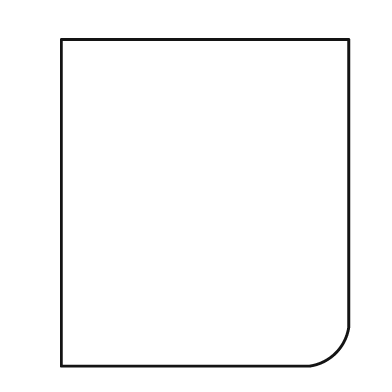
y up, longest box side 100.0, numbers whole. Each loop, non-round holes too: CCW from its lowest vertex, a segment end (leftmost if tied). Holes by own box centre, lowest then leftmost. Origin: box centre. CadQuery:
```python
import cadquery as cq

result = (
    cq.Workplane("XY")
    .moveTo(-44.0, -50.0)
    .lineTo(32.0, -50.0)
    .threePointArc((40.0, -46.0), (44.0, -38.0))
    .lineTo(44.0, 50.0)
    .lineTo(-44.0, 50.0)
    .close()
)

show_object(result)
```